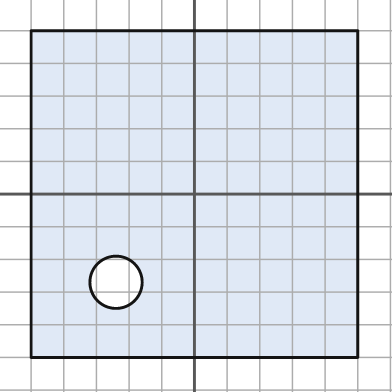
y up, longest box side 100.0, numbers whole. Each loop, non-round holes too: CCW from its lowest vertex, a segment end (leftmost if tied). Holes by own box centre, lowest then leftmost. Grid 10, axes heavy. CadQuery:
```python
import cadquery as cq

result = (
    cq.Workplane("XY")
    .moveTo(-50.0, -50.0)
    .lineTo(50.0, -50.0)
    .lineTo(50.0, 50.0)
    .lineTo(-50.0, 50.0)
    .close()
    .moveTo(-24.0, -27.0)
    .circle(8.0)
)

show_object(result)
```